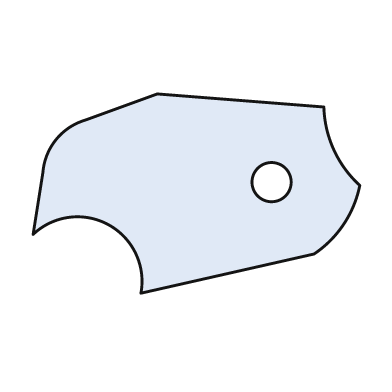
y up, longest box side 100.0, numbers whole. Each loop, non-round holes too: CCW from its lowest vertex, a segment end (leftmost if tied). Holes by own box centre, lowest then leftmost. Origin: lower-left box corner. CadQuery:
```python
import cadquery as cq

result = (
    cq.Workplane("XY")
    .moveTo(33.0, 0.0)
    .lineTo(86.0, 12.0)
    .threePointArc((95.0, 21.0), (100.0, 33.0))
    .threePointArc((92.0, 44.0), (89.0, 57.0))
    .lineTo(38.0, 61.0)
    .lineTo(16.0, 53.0)
    .threePointArc((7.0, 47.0), (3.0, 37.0))
    .lineTo(0.0, 18.0)
    .threePointArc((23.0, 21.0), (33.0, 0.0))
    .close()
    .moveTo(73.0, 34.0)
    .circle(6.0)
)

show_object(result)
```